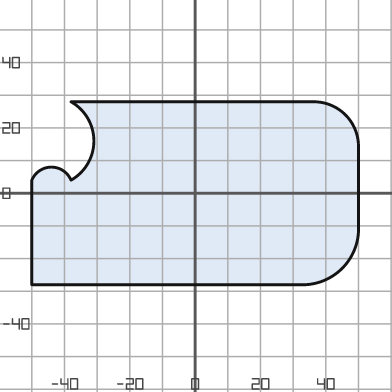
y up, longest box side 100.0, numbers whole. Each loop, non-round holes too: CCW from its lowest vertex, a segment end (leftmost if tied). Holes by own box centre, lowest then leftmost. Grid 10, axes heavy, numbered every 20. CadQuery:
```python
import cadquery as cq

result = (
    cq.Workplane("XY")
    .moveTo(-50.0, -28.0)
    .lineTo(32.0, -28.0)
    .threePointArc((45.0, -23.0), (50.0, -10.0))
    .lineTo(50.0, 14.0)
    .threePointArc((46.0, 24.0), (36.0, 28.0))
    .lineTo(-38.0, 28.0)
    .threePointArc((-31.0, 16.0), (-38.0, 4.0))
    .threePointArc((-44.0, 8.0), (-50.0, 4.0))
    .close()
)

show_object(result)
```